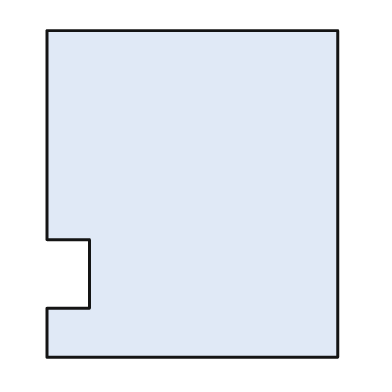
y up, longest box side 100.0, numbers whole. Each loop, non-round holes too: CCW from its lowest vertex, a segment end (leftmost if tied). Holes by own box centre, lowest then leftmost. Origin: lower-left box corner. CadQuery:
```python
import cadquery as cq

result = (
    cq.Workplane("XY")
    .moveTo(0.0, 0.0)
    .lineTo(89.0, 0.0)
    .lineTo(89.0, 100.0)
    .lineTo(0.0, 100.0)
    .lineTo(0.0, 36.0)
    .lineTo(13.0, 36.0)
    .lineTo(13.0, 15.0)
    .lineTo(0.0, 15.0)
    .close()
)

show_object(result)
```